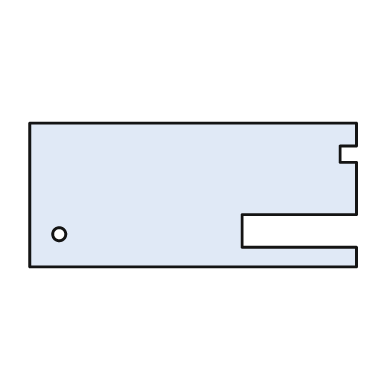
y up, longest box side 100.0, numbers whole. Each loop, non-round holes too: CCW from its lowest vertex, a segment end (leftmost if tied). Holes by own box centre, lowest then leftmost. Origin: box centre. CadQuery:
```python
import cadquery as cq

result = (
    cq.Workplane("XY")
    .moveTo(-50.0, -22.0)
    .lineTo(50.0, -22.0)
    .lineTo(50.0, -16.0)
    .lineTo(15.0, -16.0)
    .lineTo(15.0, -6.0)
    .lineTo(50.0, -6.0)
    .lineTo(50.0, 10.0)
    .lineTo(45.0, 10.0)
    .lineTo(45.0, 15.0)
    .lineTo(50.0, 15.0)
    .lineTo(50.0, 22.0)
    .lineTo(-50.0, 22.0)
    .close()
    .moveTo(-41.0, -12.0)
    .circle(2.0)
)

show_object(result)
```